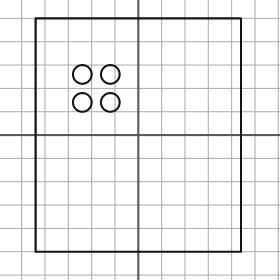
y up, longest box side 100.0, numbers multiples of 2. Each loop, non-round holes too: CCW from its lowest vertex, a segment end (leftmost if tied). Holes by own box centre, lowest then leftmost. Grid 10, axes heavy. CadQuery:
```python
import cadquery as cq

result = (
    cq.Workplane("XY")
    .moveTo(-44.0, -50.0)
    .lineTo(44.0, -50.0)
    .lineTo(44.0, 50.0)
    .lineTo(-44.0, 50.0)
    .close()
    .moveTo(-24.0, 14.0)
    .circle(4.0)
    .moveTo(-12.0, 14.0)
    .circle(4.0)
    .moveTo(-24.0, 26.0)
    .circle(4.0)
    .moveTo(-12.0, 26.0)
    .circle(4.0)
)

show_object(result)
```